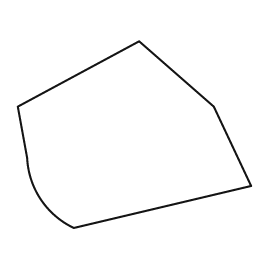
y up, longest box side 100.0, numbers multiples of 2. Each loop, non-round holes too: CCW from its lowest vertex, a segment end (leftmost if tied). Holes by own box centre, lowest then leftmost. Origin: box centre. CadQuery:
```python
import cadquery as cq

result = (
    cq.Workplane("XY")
    .moveTo(-26.0, -40.0)
    .lineTo(50.0, -22.0)
    .lineTo(34.0, 12.0)
    .lineTo(2.0, 40.0)
    .lineTo(-50.0, 12.0)
    .lineTo(-46.0, -10.0)
    .threePointArc((-40.0, -28.0), (-26.0, -40.0))
    .close()
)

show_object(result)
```